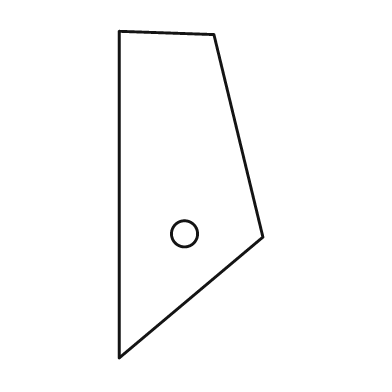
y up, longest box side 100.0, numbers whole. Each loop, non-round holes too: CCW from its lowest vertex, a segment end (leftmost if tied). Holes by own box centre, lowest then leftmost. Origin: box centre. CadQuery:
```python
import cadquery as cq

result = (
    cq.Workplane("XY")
    .moveTo(-22.0, -50.0)
    .lineTo(22.0, -13.0)
    .lineTo(7.0, 49.0)
    .lineTo(-22.0, 50.0)
    .close()
    .moveTo(-2.0, -12.0)
    .circle(4.0)
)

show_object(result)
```